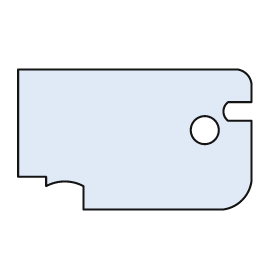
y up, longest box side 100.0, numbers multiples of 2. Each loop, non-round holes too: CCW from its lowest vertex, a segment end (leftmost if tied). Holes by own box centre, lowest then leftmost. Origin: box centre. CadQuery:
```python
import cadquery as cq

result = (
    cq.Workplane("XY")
    .moveTo(-22.0, -30.0)
    .lineTo(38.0, -30.0)
    .threePointArc((46.0, -26.0), (50.0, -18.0))
    .lineTo(50.0, 8.0)
    .lineTo(40.0, 8.0)
    .threePointArc((38.0, 12.0), (40.0, 16.0))
    .lineTo(50.0, 16.0)
    .lineTo(50.0, 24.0)
    .threePointArc((48.0, 28.0), (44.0, 30.0))
    .lineTo(-50.0, 30.0)
    .lineTo(-50.0, -16.0)
    .lineTo(-38.0, -16.0)
    .lineTo(-38.0, -20.0)
    .threePointArc((-30.0, -18.0), (-22.0, -20.0))
    .close()
    .moveTo(30.0, 4.0)
    .circle(6.0)
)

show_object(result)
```